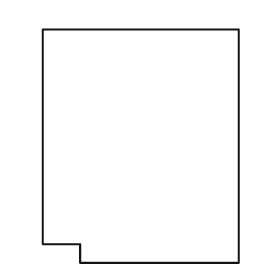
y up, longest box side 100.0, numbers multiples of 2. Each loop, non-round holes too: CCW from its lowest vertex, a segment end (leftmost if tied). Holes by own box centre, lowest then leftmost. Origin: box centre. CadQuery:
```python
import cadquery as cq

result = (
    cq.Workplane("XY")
    .moveTo(-26.0, -50.0)
    .lineTo(42.0, -50.0)
    .lineTo(42.0, 50.0)
    .lineTo(-42.0, 50.0)
    .lineTo(-42.0, -42.0)
    .lineTo(-26.0, -42.0)
    .close()
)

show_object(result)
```